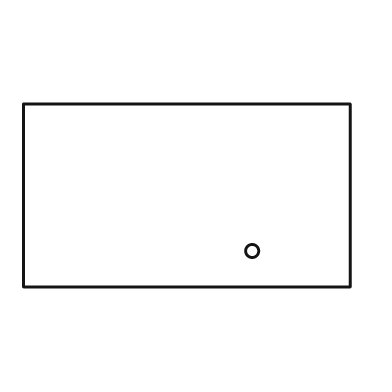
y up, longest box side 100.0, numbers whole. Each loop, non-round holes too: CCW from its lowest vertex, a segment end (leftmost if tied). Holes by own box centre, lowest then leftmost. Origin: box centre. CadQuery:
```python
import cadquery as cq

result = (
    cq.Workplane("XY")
    .moveTo(-50.0, -28.0)
    .lineTo(50.0, -28.0)
    .lineTo(50.0, 28.0)
    .lineTo(-50.0, 28.0)
    .close()
    .moveTo(20.0, -17.0)
    .circle(2.0)
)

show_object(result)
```